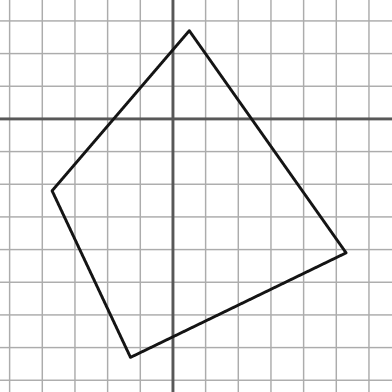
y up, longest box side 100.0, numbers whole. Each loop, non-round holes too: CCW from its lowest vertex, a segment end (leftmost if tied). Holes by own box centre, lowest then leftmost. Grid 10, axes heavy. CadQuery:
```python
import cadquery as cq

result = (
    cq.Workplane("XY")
    .moveTo(-13.0, -73.0)
    .lineTo(53.0, -41.0)
    .lineTo(5.0, 27.0)
    .lineTo(-37.0, -22.0)
    .close()
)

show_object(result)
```